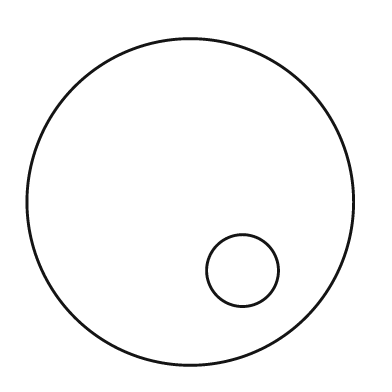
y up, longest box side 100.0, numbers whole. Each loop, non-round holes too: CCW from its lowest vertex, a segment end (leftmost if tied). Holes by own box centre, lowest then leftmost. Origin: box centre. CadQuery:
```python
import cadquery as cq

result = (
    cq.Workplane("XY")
    .moveTo(0.0, 0.0)
    .circle(50.0)
    .moveTo(16.0, -21.0)
    .circle(11.0)
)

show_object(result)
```